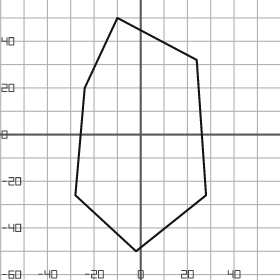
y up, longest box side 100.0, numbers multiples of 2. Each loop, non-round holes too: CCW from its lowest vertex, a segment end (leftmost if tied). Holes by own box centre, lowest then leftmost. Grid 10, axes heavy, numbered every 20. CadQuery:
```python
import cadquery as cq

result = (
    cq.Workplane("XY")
    .moveTo(-2.0, -50.0)
    .lineTo(28.0, -26.0)
    .lineTo(24.0, 32.0)
    .lineTo(-10.0, 50.0)
    .lineTo(-24.0, 20.0)
    .lineTo(-28.0, -26.0)
    .close()
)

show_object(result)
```